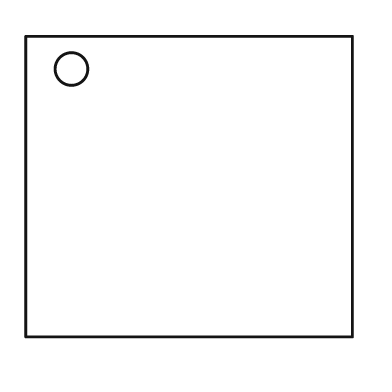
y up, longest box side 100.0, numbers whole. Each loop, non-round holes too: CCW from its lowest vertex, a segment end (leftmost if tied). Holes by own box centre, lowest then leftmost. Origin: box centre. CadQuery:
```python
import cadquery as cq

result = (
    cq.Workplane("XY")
    .moveTo(-50.0, -46.0)
    .lineTo(50.0, -46.0)
    .lineTo(50.0, 46.0)
    .lineTo(-50.0, 46.0)
    .close()
    .moveTo(-36.0, 36.0)
    .circle(5.0)
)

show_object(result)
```